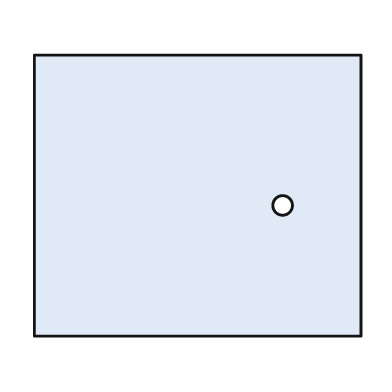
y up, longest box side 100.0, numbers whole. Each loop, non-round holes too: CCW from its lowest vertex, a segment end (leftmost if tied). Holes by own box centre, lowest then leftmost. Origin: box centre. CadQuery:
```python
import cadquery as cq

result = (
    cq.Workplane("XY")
    .moveTo(-50.0, -43.0)
    .lineTo(50.0, -43.0)
    .lineTo(50.0, 43.0)
    .lineTo(-50.0, 43.0)
    .close()
    .moveTo(26.0, -3.0)
    .circle(3.0)
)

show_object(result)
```